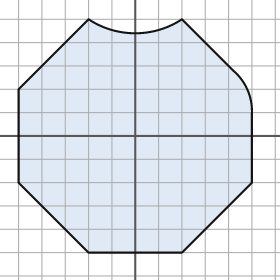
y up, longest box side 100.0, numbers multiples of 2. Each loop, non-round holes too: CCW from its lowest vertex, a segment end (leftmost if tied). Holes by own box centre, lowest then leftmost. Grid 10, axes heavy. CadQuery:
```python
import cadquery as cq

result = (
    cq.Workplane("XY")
    .moveTo(-20.0, -50.0)
    .lineTo(20.0, -50.0)
    .lineTo(50.0, -20.0)
    .lineTo(50.0, 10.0)
    .threePointArc((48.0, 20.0), (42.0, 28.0))
    .lineTo(20.0, 50.0)
    .threePointArc((0.0, 44.0), (-20.0, 50.0))
    .lineTo(-50.0, 20.0)
    .lineTo(-50.0, -20.0)
    .close()
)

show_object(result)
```